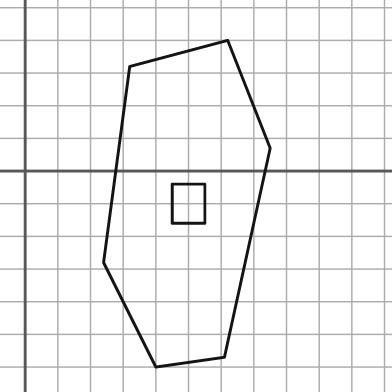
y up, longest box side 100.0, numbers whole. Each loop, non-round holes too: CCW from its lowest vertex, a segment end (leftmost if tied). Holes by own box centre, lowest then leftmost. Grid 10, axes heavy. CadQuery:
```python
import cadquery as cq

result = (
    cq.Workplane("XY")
    .moveTo(40.0, -60.0)
    .lineTo(61.0, -57.0)
    .lineTo(75.0, 7.0)
    .lineTo(62.0, 40.0)
    .lineTo(32.0, 32.0)
    .lineTo(24.0, -28.0)
    .close()
    .moveTo(45.0, -16.0)
    .lineTo(55.0, -16.0)
    .lineTo(55.0, -4.0)
    .lineTo(45.0, -4.0)
    .close()
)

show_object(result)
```